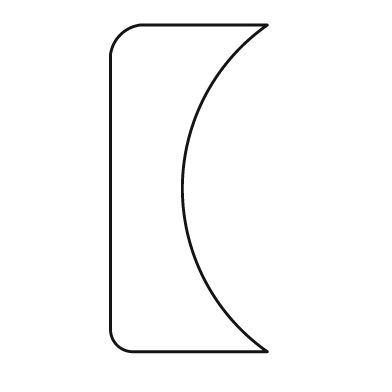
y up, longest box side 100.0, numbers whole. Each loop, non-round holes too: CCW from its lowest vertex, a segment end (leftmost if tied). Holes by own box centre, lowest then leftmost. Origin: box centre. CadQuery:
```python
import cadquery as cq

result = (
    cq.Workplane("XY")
    .moveTo(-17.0, -50.0)
    .lineTo(24.0, -50.0)
    .threePointArc((-2.0, 0.0), (24.0, 50.0))
    .lineTo(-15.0, 50.0)
    .threePointArc((-21.0, 47.0), (-24.0, 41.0))
    .lineTo(-24.0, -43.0)
    .threePointArc((-22.0, -48.0), (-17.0, -50.0))
    .close()
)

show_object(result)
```